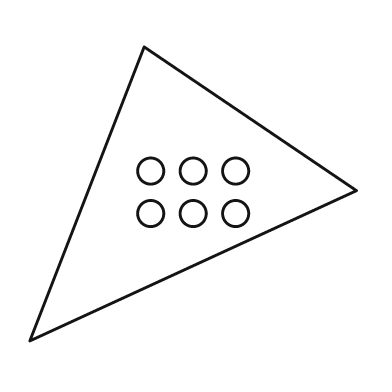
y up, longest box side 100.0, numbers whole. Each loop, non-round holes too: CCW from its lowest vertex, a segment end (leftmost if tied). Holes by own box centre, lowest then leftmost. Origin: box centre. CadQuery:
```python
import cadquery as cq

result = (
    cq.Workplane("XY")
    .moveTo(-50.0, -45.0)
    .lineTo(50.0, 1.0)
    .lineTo(-15.0, 45.0)
    .close()
    .moveTo(-13.0, -6.0)
    .circle(4.0)
    .moveTo(0.0, -6.0)
    .circle(4.0)
    .moveTo(13.0, -6.0)
    .circle(4.0)
    .moveTo(-13.0, 7.0)
    .circle(4.0)
    .moveTo(0.0, 7.0)
    .circle(4.0)
    .moveTo(13.0, 7.0)
    .circle(4.0)
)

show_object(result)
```